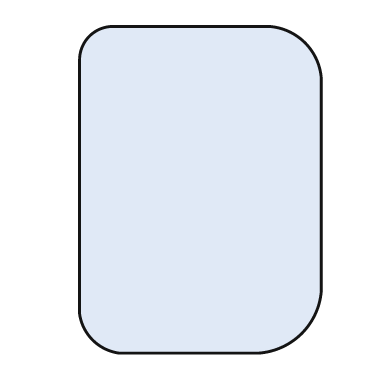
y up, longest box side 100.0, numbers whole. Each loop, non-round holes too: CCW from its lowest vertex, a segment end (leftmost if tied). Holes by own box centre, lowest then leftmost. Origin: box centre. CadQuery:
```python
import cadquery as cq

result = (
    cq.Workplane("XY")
    .moveTo(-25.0, -50.0)
    .lineTo(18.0, -50.0)
    .threePointArc((31.0, -44.0), (37.0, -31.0))
    .lineTo(37.0, 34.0)
    .threePointArc((32.0, 45.0), (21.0, 50.0))
    .lineTo(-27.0, 50.0)
    .threePointArc((-34.0, 47.0), (-37.0, 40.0))
    .lineTo(-37.0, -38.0)
    .threePointArc((-33.0, -46.0), (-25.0, -50.0))
    .close()
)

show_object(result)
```